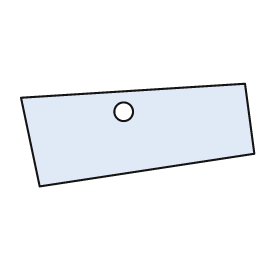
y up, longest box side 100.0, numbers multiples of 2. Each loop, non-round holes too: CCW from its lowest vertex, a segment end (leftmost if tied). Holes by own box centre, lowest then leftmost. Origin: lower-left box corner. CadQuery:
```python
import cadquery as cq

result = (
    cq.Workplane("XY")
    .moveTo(8.0, 0.0)
    .lineTo(100.0, 14.0)
    .lineTo(96.0, 44.0)
    .lineTo(0.0, 38.0)
    .close()
    .moveTo(44.0, 32.0)
    .circle(4.0)
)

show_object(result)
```